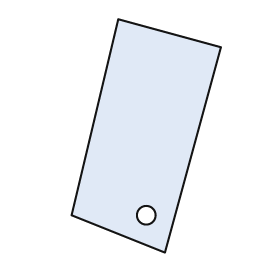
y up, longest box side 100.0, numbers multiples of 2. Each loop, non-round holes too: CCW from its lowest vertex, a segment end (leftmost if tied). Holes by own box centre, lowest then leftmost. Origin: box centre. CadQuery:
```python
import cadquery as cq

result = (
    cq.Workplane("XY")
    .moveTo(8.0, -50.0)
    .lineTo(32.0, 38.0)
    .lineTo(-12.0, 50.0)
    .lineTo(-32.0, -34.0)
    .close()
    .moveTo(0.0, -34.0)
    .circle(4.0)
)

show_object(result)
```